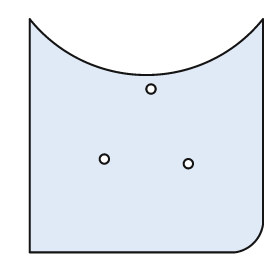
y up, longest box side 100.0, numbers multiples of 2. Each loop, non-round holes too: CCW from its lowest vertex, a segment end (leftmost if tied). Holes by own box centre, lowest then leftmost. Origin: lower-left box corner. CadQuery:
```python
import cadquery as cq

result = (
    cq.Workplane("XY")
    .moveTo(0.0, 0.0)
    .lineTo(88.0, 0.0)
    .threePointArc((96.0, 4.0), (100.0, 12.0))
    .lineTo(100.0, 100.0)
    .threePointArc((50.0, 76.0), (0.0, 100.0))
    .close()
    .moveTo(68.0, 38.0)
    .circle(2.0)
    .moveTo(32.0, 40.0)
    .circle(2.0)
    .moveTo(52.0, 70.0)
    .circle(2.0)
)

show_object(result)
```